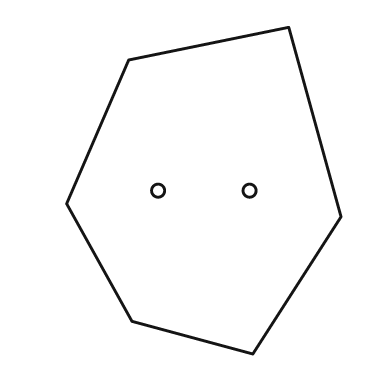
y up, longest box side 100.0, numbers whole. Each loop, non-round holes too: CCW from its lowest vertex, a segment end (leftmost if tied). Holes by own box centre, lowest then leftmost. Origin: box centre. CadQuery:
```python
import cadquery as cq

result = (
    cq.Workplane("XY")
    .moveTo(15.0, -50.0)
    .lineTo(42.0, -8.0)
    .lineTo(26.0, 50.0)
    .lineTo(-23.0, 40.0)
    .lineTo(-42.0, -4.0)
    .lineTo(-22.0, -40.0)
    .close()
    .moveTo(-14.0, 0.0)
    .circle(2.0)
    .moveTo(14.0, 0.0)
    .circle(2.0)
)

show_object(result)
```